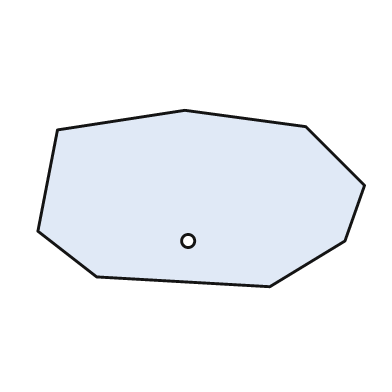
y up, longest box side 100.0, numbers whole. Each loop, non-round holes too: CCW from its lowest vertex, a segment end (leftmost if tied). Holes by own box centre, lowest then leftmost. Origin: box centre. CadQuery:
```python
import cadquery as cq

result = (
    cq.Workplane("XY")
    .moveTo(21.0, -27.0)
    .lineTo(44.0, -13.0)
    .lineTo(50.0, 4.0)
    .lineTo(32.0, 22.0)
    .lineTo(-5.0, 27.0)
    .lineTo(-44.0, 21.0)
    .lineTo(-50.0, -10.0)
    .lineTo(-32.0, -24.0)
    .close()
    .moveTo(-4.0, -13.0)
    .circle(2.0)
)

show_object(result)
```